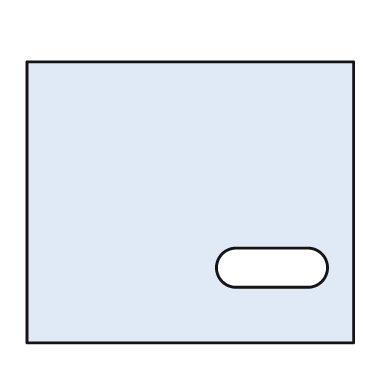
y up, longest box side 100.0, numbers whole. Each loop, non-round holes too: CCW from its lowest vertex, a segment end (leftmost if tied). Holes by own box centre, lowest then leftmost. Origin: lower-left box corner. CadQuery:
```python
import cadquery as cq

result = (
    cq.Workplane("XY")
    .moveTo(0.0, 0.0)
    .lineTo(100.0, 0.0)
    .lineTo(100.0, 86.0)
    .lineTo(0.0, 86.0)
    .close()
    .moveTo(64.0, 17.0)
    .lineTo(86.0, 17.0)
    .threePointArc((92.0, 23.0), (86.0, 29.0))
    .lineTo(64.0, 29.0)
    .threePointArc((58.0, 23.0), (64.0, 17.0))
    .close()
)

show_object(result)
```